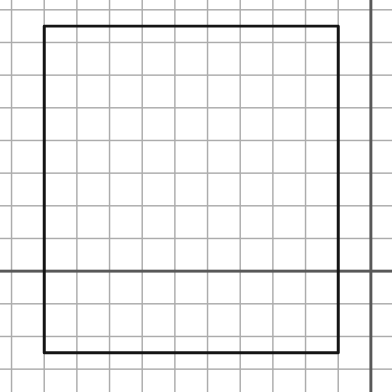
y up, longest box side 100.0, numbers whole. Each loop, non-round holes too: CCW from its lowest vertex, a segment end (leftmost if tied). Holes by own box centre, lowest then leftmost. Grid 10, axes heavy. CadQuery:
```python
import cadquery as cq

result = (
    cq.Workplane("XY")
    .moveTo(-100.0, -25.0)
    .lineTo(-10.0, -25.0)
    .lineTo(-10.0, 75.0)
    .lineTo(-100.0, 75.0)
    .close()
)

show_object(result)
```